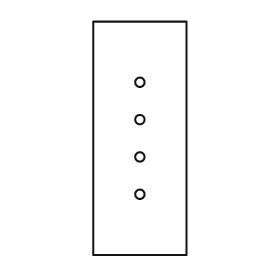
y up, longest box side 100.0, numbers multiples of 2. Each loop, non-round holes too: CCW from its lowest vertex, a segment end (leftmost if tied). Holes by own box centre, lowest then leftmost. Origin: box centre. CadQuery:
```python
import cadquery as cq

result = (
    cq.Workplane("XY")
    .moveTo(-20.0, -50.0)
    .lineTo(20.0, -50.0)
    .lineTo(20.0, 50.0)
    .lineTo(-20.0, 50.0)
    .close()
    .moveTo(0.0, -24.0)
    .circle(2.0)
    .moveTo(0.0, -8.0)
    .circle(2.0)
    .moveTo(0.0, 8.0)
    .circle(2.0)
    .moveTo(0.0, 24.0)
    .circle(2.0)
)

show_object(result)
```